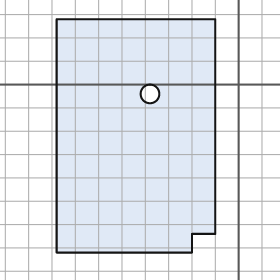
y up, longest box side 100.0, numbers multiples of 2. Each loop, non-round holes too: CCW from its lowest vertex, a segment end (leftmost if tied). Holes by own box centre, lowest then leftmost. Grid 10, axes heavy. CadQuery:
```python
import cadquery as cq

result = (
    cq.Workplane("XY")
    .moveTo(-78.0, -72.0)
    .lineTo(-20.0, -72.0)
    .lineTo(-20.0, -64.0)
    .lineTo(-10.0, -64.0)
    .lineTo(-10.0, 28.0)
    .lineTo(-78.0, 28.0)
    .close()
    .moveTo(-38.0, -4.0)
    .circle(4.0)
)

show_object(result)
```